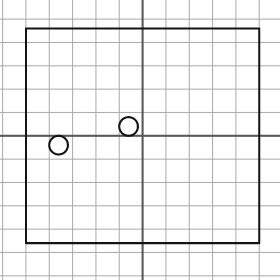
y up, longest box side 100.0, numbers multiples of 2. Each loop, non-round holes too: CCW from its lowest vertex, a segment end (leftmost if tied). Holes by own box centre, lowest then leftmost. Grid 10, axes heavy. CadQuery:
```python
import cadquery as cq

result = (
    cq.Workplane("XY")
    .moveTo(-50.0, -46.0)
    .lineTo(50.0, -46.0)
    .lineTo(50.0, 46.0)
    .lineTo(-50.0, 46.0)
    .close()
    .moveTo(-36.0, -4.0)
    .circle(4.0)
    .moveTo(-6.0, 4.0)
    .circle(4.0)
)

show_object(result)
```